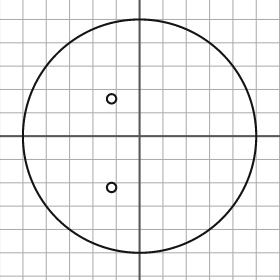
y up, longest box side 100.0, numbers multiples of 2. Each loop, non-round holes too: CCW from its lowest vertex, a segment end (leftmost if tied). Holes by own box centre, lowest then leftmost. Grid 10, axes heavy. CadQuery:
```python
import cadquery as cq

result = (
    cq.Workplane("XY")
    .moveTo(0.0, 0.0)
    .circle(50.0)
    .moveTo(-12.0, -22.0)
    .circle(2.0)
    .moveTo(-12.0, 16.0)
    .circle(2.0)
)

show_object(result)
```